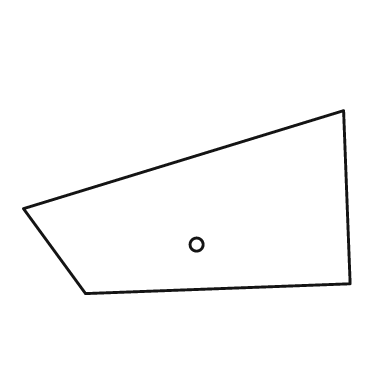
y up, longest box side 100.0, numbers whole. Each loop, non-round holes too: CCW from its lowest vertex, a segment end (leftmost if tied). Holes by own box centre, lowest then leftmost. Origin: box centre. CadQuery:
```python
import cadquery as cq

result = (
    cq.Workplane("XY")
    .moveTo(-31.0, -28.0)
    .lineTo(50.0, -25.0)
    .lineTo(48.0, 28.0)
    .lineTo(-50.0, -2.0)
    .close()
    .moveTo(3.0, -13.0)
    .circle(2.0)
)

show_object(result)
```